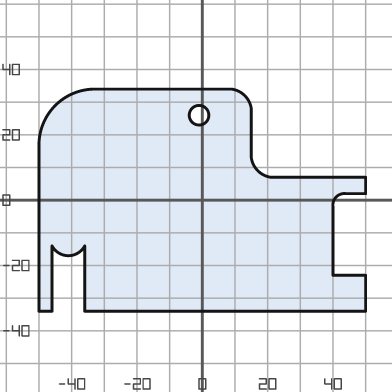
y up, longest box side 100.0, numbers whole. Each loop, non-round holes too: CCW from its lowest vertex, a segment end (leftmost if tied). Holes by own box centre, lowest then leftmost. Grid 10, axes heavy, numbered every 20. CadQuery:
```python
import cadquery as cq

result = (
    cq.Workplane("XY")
    .moveTo(-50.0, -34.0)
    .lineTo(-46.0, -34.0)
    .lineTo(-46.0, -14.0)
    .threePointArc((-41.0, -17.0), (-36.0, -14.0))
    .lineTo(-36.0, -34.0)
    .lineTo(50.0, -34.0)
    .lineTo(50.0, -23.0)
    .lineTo(40.0, -23.0)
    .lineTo(40.0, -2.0)
    .threePointArc((41.0, 1.0), (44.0, 2.0))
    .lineTo(50.0, 2.0)
    .lineTo(50.0, 7.0)
    .lineTo(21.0, 7.0)
    .threePointArc((17.0, 9.0), (15.0, 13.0))
    .lineTo(15.0, 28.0)
    .threePointArc((13.0, 32.0), (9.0, 34.0))
    .lineTo(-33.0, 34.0)
    .threePointArc((-45.0, 29.0), (-50.0, 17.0))
    .close()
    .moveTo(-1.0, 26.0)
    .circle(3.0)
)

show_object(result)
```